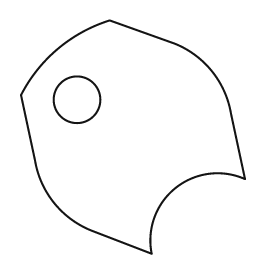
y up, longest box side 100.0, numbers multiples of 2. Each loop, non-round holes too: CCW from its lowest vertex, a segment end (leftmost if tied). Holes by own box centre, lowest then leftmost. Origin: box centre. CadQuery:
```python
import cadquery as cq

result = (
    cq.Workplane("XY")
    .moveTo(8.0, -50.0)
    .threePointArc((18.0, -22.0), (48.0, -18.0))
    .lineTo(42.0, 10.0)
    .threePointArc((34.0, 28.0), (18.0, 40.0))
    .lineTo(-10.0, 50.0)
    .threePointArc((-32.0, 38.0), (-48.0, 18.0))
    .lineTo(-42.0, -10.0)
    .threePointArc((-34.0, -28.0), (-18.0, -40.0))
    .close()
    .moveTo(-24.0, 16.0)
    .circle(10.0)
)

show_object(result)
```